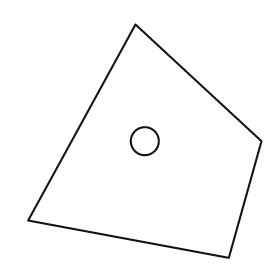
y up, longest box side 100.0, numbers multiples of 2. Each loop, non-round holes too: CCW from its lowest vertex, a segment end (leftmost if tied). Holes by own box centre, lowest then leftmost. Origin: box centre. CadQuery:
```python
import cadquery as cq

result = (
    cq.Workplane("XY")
    .moveTo(36.0, -50.0)
    .lineTo(50.0, 0.0)
    .lineTo(-4.0, 50.0)
    .lineTo(-50.0, -34.0)
    .close()
    .moveTo(0.0, 0.0)
    .circle(6.0)
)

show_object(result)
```